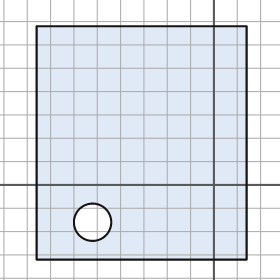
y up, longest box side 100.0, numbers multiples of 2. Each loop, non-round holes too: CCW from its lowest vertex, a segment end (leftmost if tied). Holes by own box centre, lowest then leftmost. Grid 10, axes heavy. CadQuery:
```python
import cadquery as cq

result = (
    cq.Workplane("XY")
    .moveTo(-76.0, -32.0)
    .lineTo(14.0, -32.0)
    .lineTo(14.0, 68.0)
    .lineTo(-76.0, 68.0)
    .close()
    .moveTo(-52.0, -16.0)
    .circle(8.0)
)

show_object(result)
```